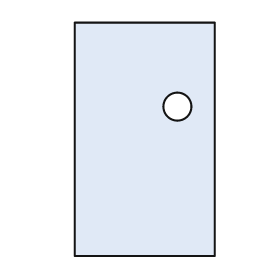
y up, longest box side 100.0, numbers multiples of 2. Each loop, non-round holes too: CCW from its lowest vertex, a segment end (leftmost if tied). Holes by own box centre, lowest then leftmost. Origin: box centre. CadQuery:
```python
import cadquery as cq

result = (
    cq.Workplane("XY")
    .moveTo(-30.0, -50.0)
    .lineTo(30.0, -50.0)
    .lineTo(30.0, 50.0)
    .lineTo(-30.0, 50.0)
    .close()
    .moveTo(14.0, 14.0)
    .circle(6.0)
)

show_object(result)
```